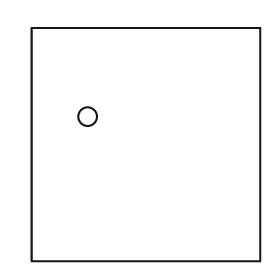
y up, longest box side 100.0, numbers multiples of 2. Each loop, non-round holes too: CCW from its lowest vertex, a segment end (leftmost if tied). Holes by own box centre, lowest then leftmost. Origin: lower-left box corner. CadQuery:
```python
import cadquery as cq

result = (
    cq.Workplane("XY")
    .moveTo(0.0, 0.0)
    .lineTo(98.0, 0.0)
    .lineTo(98.0, 100.0)
    .lineTo(0.0, 100.0)
    .close()
    .moveTo(24.0, 62.0)
    .circle(4.0)
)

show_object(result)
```